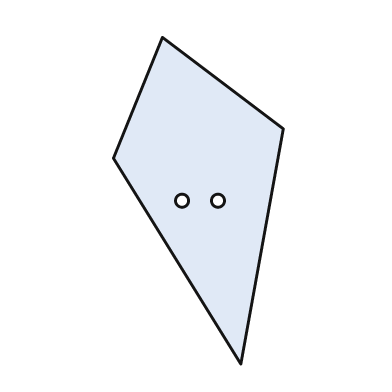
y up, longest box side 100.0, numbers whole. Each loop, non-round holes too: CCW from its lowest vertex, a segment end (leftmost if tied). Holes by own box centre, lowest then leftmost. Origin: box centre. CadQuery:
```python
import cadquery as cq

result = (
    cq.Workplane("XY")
    .moveTo(13.0, -50.0)
    .lineTo(26.0, 22.0)
    .lineTo(-11.0, 50.0)
    .lineTo(-26.0, 13.0)
    .close()
    .moveTo(-5.0, 0.0)
    .circle(2.0)
    .moveTo(6.0, 0.0)
    .circle(2.0)
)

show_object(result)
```